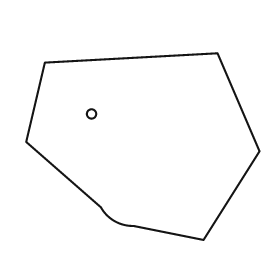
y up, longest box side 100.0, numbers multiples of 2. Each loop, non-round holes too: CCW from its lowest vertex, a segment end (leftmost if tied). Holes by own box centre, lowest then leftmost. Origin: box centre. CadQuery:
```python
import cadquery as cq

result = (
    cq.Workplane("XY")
    .moveTo(26.0, -40.0)
    .lineTo(50.0, -2.0)
    .lineTo(32.0, 40.0)
    .lineTo(-42.0, 36.0)
    .lineTo(-50.0, 2.0)
    .lineTo(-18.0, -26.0)
    .threePointArc((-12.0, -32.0), (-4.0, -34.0))
    .close()
    .moveTo(-22.0, 14.0)
    .circle(2.0)
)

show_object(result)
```